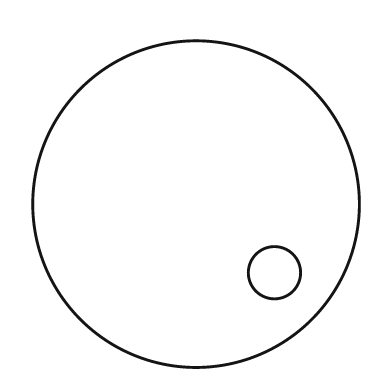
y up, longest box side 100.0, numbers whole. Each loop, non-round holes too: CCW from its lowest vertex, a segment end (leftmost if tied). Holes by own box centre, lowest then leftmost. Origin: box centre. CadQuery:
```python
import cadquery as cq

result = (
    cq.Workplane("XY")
    .moveTo(0.0, 0.0)
    .circle(50.0)
    .moveTo(24.0, -21.0)
    .circle(8.0)
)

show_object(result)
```